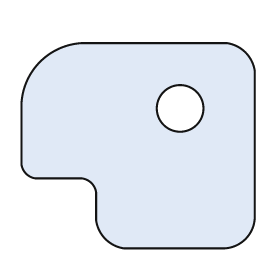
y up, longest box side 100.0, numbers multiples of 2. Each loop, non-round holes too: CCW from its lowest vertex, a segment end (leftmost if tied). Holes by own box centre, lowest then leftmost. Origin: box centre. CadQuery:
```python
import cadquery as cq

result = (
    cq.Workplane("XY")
    .moveTo(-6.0, -44.0)
    .lineTo(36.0, -44.0)
    .threePointArc((46.0, -40.0), (50.0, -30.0))
    .lineTo(50.0, 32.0)
    .threePointArc((46.0, 40.0), (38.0, 44.0))
    .lineTo(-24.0, 44.0)
    .threePointArc((-42.0, 36.0), (-50.0, 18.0))
    .lineTo(-50.0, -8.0)
    .threePointArc((-48.0, -12.0), (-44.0, -14.0))
    .lineTo(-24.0, -14.0)
    .threePointArc((-20.0, -16.0), (-18.0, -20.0))
    .lineTo(-18.0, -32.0)
    .threePointArc((-14.0, -40.0), (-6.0, -44.0))
    .close()
    .moveTo(18.0, 16.0)
    .circle(10.0)
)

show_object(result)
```